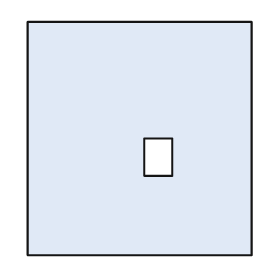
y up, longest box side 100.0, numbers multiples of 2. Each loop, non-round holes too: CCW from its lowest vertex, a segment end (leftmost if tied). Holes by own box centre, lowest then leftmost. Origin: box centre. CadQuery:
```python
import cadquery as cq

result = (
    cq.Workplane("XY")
    .moveTo(-48.0, -50.0)
    .lineTo(48.0, -50.0)
    .lineTo(48.0, 50.0)
    .lineTo(-48.0, 50.0)
    .close()
    .moveTo(2.0, -16.0)
    .lineTo(14.0, -16.0)
    .lineTo(14.0, 0.0)
    .lineTo(2.0, 0.0)
    .close()
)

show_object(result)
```